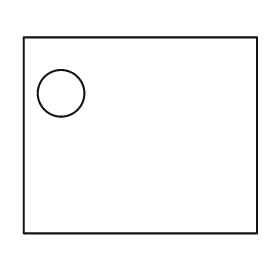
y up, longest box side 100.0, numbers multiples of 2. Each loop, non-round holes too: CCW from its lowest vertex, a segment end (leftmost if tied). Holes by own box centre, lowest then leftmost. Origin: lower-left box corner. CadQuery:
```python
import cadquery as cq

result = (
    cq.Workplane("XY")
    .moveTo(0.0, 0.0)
    .lineTo(100.0, 0.0)
    .lineTo(100.0, 84.0)
    .lineTo(0.0, 84.0)
    .close()
    .moveTo(16.0, 60.0)
    .circle(10.0)
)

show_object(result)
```